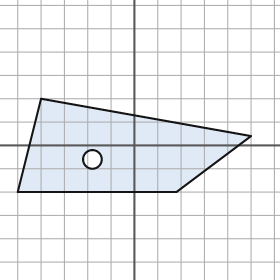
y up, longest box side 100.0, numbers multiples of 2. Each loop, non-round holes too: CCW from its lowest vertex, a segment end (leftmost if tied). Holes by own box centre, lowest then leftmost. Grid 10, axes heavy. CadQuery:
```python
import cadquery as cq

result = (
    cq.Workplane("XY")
    .moveTo(-50.0, -20.0)
    .lineTo(18.0, -20.0)
    .lineTo(50.0, 4.0)
    .lineTo(-40.0, 20.0)
    .close()
    .moveTo(-18.0, -6.0)
    .circle(4.0)
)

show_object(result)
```